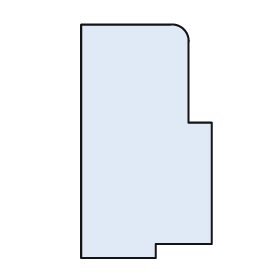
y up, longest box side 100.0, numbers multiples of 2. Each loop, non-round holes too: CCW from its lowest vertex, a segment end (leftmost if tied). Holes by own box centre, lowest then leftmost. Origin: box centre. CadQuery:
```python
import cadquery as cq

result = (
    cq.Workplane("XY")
    .moveTo(-28.0, -50.0)
    .lineTo(4.0, -50.0)
    .lineTo(4.0, -44.0)
    .lineTo(28.0, -44.0)
    .lineTo(28.0, 8.0)
    .lineTo(18.0, 8.0)
    .lineTo(18.0, 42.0)
    .threePointArc((16.0, 48.0), (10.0, 50.0))
    .lineTo(-28.0, 50.0)
    .close()
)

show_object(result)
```